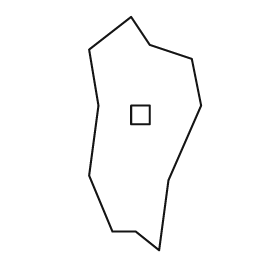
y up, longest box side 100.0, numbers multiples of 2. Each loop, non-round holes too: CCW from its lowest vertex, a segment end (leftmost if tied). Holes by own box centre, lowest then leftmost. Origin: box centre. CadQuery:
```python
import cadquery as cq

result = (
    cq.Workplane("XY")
    .moveTo(6.0, -50.0)
    .lineTo(10.0, -20.0)
    .lineTo(24.0, 12.0)
    .lineTo(20.0, 32.0)
    .lineTo(2.0, 38.0)
    .lineTo(-6.0, 50.0)
    .lineTo(-24.0, 36.0)
    .lineTo(-20.0, 12.0)
    .lineTo(-24.0, -18.0)
    .lineTo(-14.0, -42.0)
    .lineTo(-4.0, -42.0)
    .close()
    .moveTo(-6.0, 4.0)
    .lineTo(2.0, 4.0)
    .lineTo(2.0, 12.0)
    .lineTo(-6.0, 12.0)
    .close()
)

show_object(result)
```